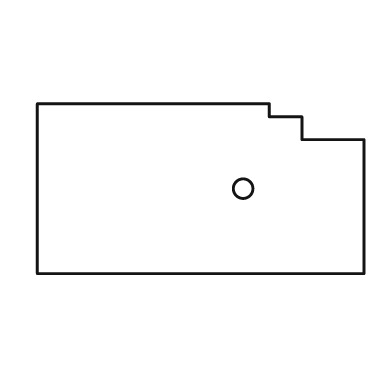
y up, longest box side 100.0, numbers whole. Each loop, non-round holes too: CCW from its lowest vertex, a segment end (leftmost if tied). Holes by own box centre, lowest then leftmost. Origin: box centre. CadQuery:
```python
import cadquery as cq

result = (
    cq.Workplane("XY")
    .moveTo(-50.0, -26.0)
    .lineTo(50.0, -26.0)
    .lineTo(50.0, 15.0)
    .lineTo(31.0, 15.0)
    .lineTo(31.0, 22.0)
    .lineTo(21.0, 22.0)
    .lineTo(21.0, 26.0)
    .lineTo(-50.0, 26.0)
    .close()
    .moveTo(13.0, 0.0)
    .circle(3.0)
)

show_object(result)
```